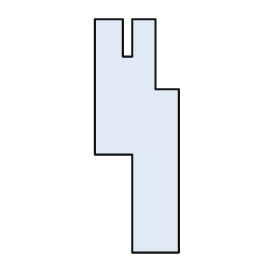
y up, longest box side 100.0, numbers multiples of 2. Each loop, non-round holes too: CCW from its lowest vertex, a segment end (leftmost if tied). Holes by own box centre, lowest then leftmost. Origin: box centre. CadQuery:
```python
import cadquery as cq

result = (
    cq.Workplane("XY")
    .moveTo(-2.0, -50.0)
    .lineTo(18.0, -50.0)
    .lineTo(18.0, 20.0)
    .lineTo(8.0, 20.0)
    .lineTo(8.0, 50.0)
    .lineTo(-2.0, 50.0)
    .lineTo(-2.0, 34.0)
    .lineTo(-6.0, 34.0)
    .lineTo(-6.0, 50.0)
    .lineTo(-18.0, 50.0)
    .lineTo(-18.0, -8.0)
    .lineTo(-2.0, -8.0)
    .close()
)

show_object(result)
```